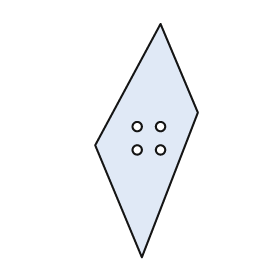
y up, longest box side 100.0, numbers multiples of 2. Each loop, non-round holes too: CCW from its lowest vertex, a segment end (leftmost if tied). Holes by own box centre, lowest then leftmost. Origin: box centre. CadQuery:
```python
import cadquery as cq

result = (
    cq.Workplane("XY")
    .moveTo(-2.0, -50.0)
    .lineTo(22.0, 12.0)
    .lineTo(6.0, 50.0)
    .lineTo(-22.0, -2.0)
    .close()
    .moveTo(-4.0, -4.0)
    .circle(2.0)
    .moveTo(6.0, -4.0)
    .circle(2.0)
    .moveTo(-4.0, 6.0)
    .circle(2.0)
    .moveTo(6.0, 6.0)
    .circle(2.0)
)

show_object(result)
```